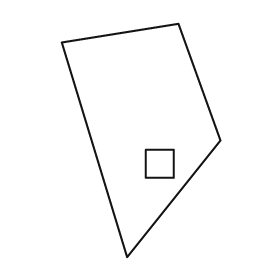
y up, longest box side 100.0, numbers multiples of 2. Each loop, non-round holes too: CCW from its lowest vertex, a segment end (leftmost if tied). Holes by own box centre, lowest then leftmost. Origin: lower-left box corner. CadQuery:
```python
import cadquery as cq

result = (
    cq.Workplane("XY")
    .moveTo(28.0, 0.0)
    .lineTo(68.0, 50.0)
    .lineTo(50.0, 100.0)
    .lineTo(0.0, 92.0)
    .close()
    .moveTo(36.0, 34.0)
    .lineTo(48.0, 34.0)
    .lineTo(48.0, 46.0)
    .lineTo(36.0, 46.0)
    .close()
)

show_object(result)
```